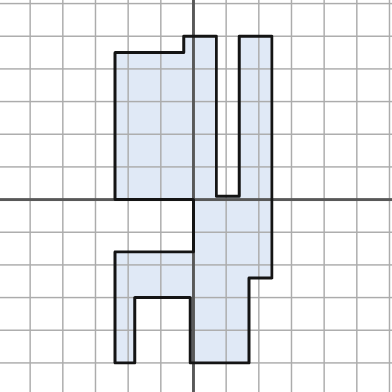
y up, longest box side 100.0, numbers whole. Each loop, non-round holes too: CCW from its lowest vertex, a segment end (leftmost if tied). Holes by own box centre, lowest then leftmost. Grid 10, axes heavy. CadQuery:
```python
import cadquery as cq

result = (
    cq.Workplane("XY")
    .moveTo(-24.0, -50.0)
    .lineTo(-18.0, -50.0)
    .lineTo(-18.0, -30.0)
    .lineTo(-1.0, -30.0)
    .lineTo(-1.0, -50.0)
    .lineTo(17.0, -50.0)
    .lineTo(17.0, -24.0)
    .lineTo(24.0, -24.0)
    .lineTo(24.0, 50.0)
    .lineTo(14.0, 50.0)
    .lineTo(14.0, 1.0)
    .lineTo(7.0, 1.0)
    .lineTo(7.0, 50.0)
    .lineTo(-3.0, 50.0)
    .lineTo(-3.0, 45.0)
    .lineTo(-24.0, 45.0)
    .lineTo(-24.0, 0.0)
    .lineTo(0.0, 0.0)
    .lineTo(0.0, -16.0)
    .lineTo(-24.0, -16.0)
    .close()
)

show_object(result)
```